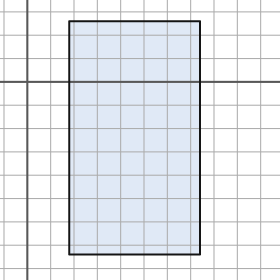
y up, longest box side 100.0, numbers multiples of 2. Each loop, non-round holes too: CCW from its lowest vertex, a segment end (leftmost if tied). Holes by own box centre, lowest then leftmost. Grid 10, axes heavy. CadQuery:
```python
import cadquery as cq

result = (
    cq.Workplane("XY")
    .moveTo(18.0, -74.0)
    .lineTo(74.0, -74.0)
    .lineTo(74.0, 26.0)
    .lineTo(18.0, 26.0)
    .close()
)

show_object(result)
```